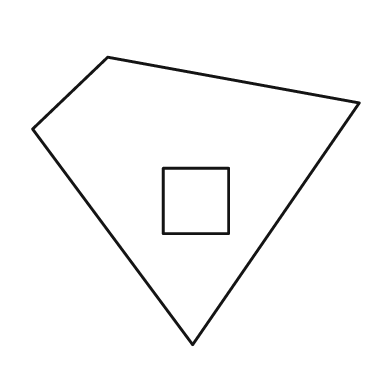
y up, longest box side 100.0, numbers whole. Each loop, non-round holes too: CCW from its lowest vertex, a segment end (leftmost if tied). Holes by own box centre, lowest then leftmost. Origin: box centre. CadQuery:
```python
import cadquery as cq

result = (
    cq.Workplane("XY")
    .moveTo(-1.0, -44.0)
    .lineTo(50.0, 30.0)
    .lineTo(-27.0, 44.0)
    .lineTo(-50.0, 22.0)
    .close()
    .moveTo(-10.0, -10.0)
    .lineTo(10.0, -10.0)
    .lineTo(10.0, 10.0)
    .lineTo(-10.0, 10.0)
    .close()
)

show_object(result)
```